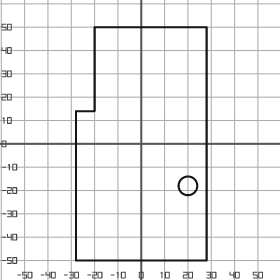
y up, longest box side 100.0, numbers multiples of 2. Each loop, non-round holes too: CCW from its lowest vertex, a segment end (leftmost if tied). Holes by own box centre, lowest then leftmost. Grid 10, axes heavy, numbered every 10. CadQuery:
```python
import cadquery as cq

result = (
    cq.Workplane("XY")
    .moveTo(-28.0, -50.0)
    .lineTo(28.0, -50.0)
    .lineTo(28.0, 50.0)
    .lineTo(-20.0, 50.0)
    .lineTo(-20.0, 14.0)
    .lineTo(-28.0, 14.0)
    .close()
    .moveTo(20.0, -18.0)
    .circle(4.0)
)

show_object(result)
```